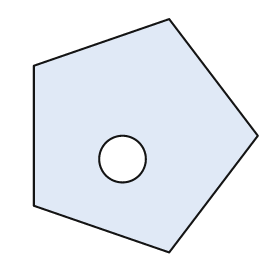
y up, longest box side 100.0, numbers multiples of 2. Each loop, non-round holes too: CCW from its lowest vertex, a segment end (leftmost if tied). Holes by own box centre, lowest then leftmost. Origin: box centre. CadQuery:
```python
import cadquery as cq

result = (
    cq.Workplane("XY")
    .moveTo(10.0, -50.0)
    .lineTo(48.0, 0.0)
    .lineTo(10.0, 50.0)
    .lineTo(-48.0, 30.0)
    .lineTo(-48.0, -30.0)
    .close()
    .moveTo(-10.0, -10.0)
    .circle(10.0)
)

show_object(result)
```